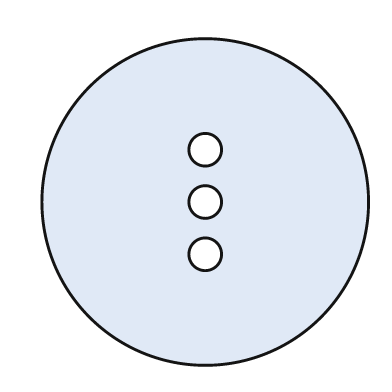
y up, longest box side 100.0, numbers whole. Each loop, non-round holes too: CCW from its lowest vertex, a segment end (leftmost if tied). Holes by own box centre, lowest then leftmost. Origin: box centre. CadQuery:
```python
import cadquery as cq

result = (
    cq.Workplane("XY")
    .moveTo(0.0, 0.0)
    .circle(50.0)
    .moveTo(0.0, -16.0)
    .circle(5.0)
    .moveTo(0.0, 0.0)
    .circle(5.0)
    .moveTo(0.0, 16.0)
    .circle(5.0)
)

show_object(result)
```